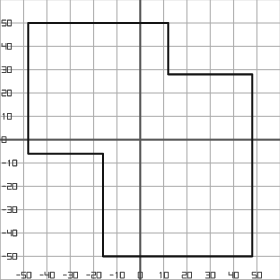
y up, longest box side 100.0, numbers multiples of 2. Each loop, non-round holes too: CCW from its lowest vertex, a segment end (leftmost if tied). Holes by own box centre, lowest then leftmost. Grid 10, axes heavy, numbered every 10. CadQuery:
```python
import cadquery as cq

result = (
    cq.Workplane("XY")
    .moveTo(-16.0, -50.0)
    .lineTo(48.0, -50.0)
    .lineTo(48.0, 28.0)
    .lineTo(12.0, 28.0)
    .lineTo(12.0, 50.0)
    .lineTo(-48.0, 50.0)
    .lineTo(-48.0, -6.0)
    .lineTo(-16.0, -6.0)
    .close()
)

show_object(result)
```